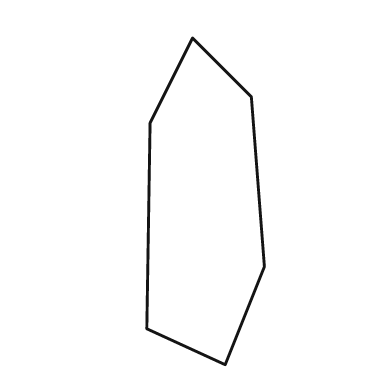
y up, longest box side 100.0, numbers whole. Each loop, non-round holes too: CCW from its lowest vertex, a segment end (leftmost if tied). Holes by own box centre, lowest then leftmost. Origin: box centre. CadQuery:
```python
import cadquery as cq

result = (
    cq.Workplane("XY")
    .moveTo(6.0, -50.0)
    .lineTo(18.0, -20.0)
    .lineTo(14.0, 32.0)
    .lineTo(-4.0, 50.0)
    .lineTo(-17.0, 24.0)
    .lineTo(-18.0, -39.0)
    .close()
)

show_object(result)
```